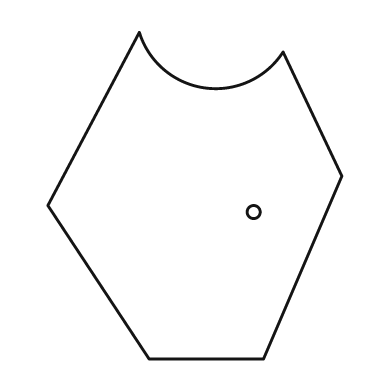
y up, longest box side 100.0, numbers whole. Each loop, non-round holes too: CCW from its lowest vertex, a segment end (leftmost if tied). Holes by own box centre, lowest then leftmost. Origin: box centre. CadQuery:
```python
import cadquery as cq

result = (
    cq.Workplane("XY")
    .moveTo(-14.0, -50.0)
    .lineTo(21.0, -50.0)
    .lineTo(45.0, 6.0)
    .lineTo(27.0, 44.0)
    .threePointArc((3.0, 33.0), (-17.0, 50.0))
    .lineTo(-45.0, -3.0)
    .close()
    .moveTo(18.0, -5.0)
    .circle(2.0)
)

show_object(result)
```